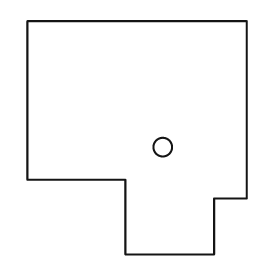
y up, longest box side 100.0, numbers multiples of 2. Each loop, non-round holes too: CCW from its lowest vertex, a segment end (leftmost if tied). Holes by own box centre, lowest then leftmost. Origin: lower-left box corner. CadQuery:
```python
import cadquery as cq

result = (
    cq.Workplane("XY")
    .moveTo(42.0, 0.0)
    .lineTo(80.0, 0.0)
    .lineTo(80.0, 24.0)
    .lineTo(94.0, 24.0)
    .lineTo(94.0, 100.0)
    .lineTo(0.0, 100.0)
    .lineTo(0.0, 32.0)
    .lineTo(42.0, 32.0)
    .close()
    .moveTo(58.0, 46.0)
    .circle(4.0)
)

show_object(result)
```